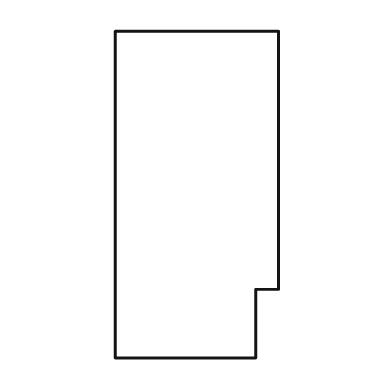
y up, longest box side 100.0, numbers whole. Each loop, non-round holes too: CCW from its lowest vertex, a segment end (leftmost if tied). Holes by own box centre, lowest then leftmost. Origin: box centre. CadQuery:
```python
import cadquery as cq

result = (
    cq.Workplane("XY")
    .moveTo(-25.0, -50.0)
    .lineTo(18.0, -50.0)
    .lineTo(18.0, -29.0)
    .lineTo(25.0, -29.0)
    .lineTo(25.0, 50.0)
    .lineTo(-25.0, 50.0)
    .close()
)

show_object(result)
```